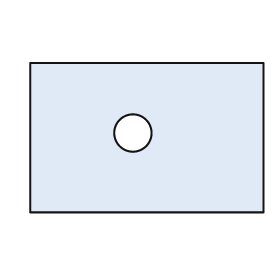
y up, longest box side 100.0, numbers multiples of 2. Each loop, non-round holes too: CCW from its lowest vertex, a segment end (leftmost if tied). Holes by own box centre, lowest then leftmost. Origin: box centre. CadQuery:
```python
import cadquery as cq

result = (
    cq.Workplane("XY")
    .moveTo(-50.0, -32.0)
    .lineTo(50.0, -32.0)
    .lineTo(50.0, 32.0)
    .lineTo(-50.0, 32.0)
    .close()
    .moveTo(-6.0, 2.0)
    .circle(8.0)
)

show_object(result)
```